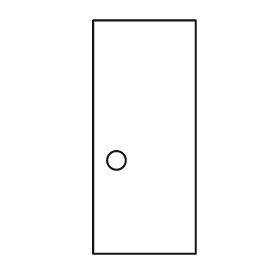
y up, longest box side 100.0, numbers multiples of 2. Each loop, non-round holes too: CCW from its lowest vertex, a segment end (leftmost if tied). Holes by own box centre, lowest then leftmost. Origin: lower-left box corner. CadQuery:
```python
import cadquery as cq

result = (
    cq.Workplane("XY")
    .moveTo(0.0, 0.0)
    .lineTo(44.0, 0.0)
    .lineTo(44.0, 100.0)
    .lineTo(0.0, 100.0)
    .close()
    .moveTo(10.0, 40.0)
    .circle(4.0)
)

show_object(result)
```